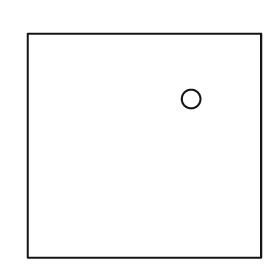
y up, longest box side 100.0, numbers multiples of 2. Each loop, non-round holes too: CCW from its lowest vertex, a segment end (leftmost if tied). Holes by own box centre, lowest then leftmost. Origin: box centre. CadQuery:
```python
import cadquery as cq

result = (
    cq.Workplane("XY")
    .moveTo(-50.0, -48.0)
    .lineTo(50.0, -48.0)
    .lineTo(50.0, 48.0)
    .lineTo(-50.0, 48.0)
    .close()
    .moveTo(20.0, 20.0)
    .circle(4.0)
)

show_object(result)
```